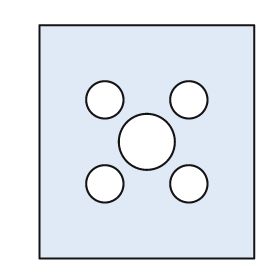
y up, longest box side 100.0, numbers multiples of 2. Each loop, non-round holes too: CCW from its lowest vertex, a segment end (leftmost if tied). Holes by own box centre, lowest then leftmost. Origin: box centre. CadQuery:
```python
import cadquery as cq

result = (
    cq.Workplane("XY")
    .moveTo(-46.0, -50.0)
    .lineTo(46.0, -50.0)
    .lineTo(46.0, 50.0)
    .lineTo(-46.0, 50.0)
    .close()
    .moveTo(-18.0, -18.0)
    .circle(8.0)
    .moveTo(18.0, -18.0)
    .circle(8.0)
    .moveTo(0.0, 0.0)
    .circle(12.0)
    .moveTo(-18.0, 18.0)
    .circle(8.0)
    .moveTo(18.0, 18.0)
    .circle(8.0)
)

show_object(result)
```